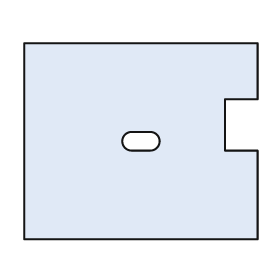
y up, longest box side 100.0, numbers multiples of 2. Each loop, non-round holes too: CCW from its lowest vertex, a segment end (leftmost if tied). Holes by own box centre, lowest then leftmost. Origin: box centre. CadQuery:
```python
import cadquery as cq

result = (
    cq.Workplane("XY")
    .moveTo(-50.0, -42.0)
    .lineTo(50.0, -42.0)
    .lineTo(50.0, -4.0)
    .lineTo(36.0, -4.0)
    .lineTo(36.0, 18.0)
    .lineTo(50.0, 18.0)
    .lineTo(50.0, 42.0)
    .lineTo(-50.0, 42.0)
    .close()
    .moveTo(-4.0, -4.0)
    .lineTo(4.0, -4.0)
    .threePointArc((8.0, 0.0), (4.0, 4.0))
    .lineTo(-4.0, 4.0)
    .threePointArc((-8.0, 0.0), (-4.0, -4.0))
    .close()
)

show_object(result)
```